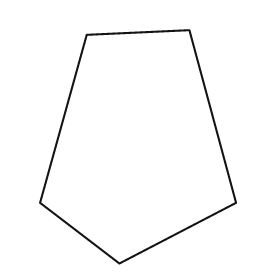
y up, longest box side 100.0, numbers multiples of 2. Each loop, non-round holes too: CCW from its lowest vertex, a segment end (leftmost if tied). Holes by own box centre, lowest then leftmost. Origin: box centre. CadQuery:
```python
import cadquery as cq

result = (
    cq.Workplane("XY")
    .moveTo(-8.0, -50.0)
    .lineTo(42.0, -24.0)
    .lineTo(22.0, 50.0)
    .lineTo(-22.0, 48.0)
    .lineTo(-42.0, -24.0)
    .close()
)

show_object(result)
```